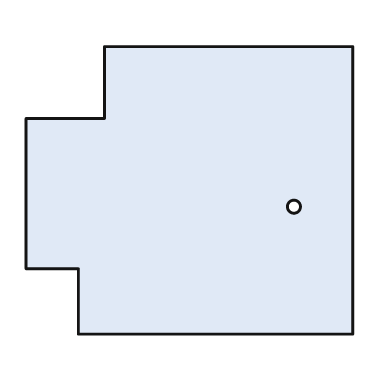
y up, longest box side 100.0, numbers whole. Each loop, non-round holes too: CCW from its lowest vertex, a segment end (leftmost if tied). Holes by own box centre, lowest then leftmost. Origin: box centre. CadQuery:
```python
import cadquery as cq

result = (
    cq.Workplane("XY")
    .moveTo(-34.0, -44.0)
    .lineTo(50.0, -44.0)
    .lineTo(50.0, 44.0)
    .lineTo(-26.0, 44.0)
    .lineTo(-26.0, 22.0)
    .lineTo(-50.0, 22.0)
    .lineTo(-50.0, -24.0)
    .lineTo(-34.0, -24.0)
    .close()
    .moveTo(32.0, -5.0)
    .circle(2.0)
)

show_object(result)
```